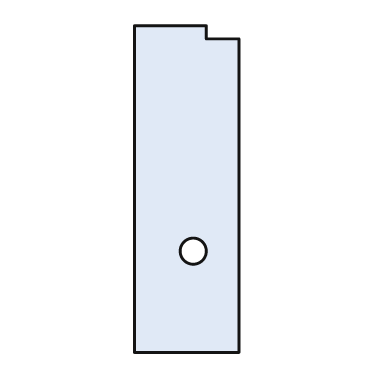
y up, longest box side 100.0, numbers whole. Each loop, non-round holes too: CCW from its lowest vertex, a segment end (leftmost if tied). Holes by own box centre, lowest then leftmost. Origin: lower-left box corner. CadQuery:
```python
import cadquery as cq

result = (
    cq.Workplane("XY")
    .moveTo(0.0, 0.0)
    .lineTo(32.0, 0.0)
    .lineTo(32.0, 96.0)
    .lineTo(22.0, 96.0)
    .lineTo(22.0, 100.0)
    .lineTo(0.0, 100.0)
    .close()
    .moveTo(18.0, 31.0)
    .circle(4.0)
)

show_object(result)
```